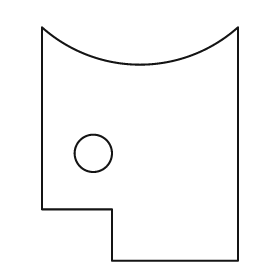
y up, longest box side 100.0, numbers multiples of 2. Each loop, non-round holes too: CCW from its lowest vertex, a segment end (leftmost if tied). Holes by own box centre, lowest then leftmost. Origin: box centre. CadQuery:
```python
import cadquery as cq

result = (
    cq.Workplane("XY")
    .moveTo(-12.0, -50.0)
    .lineTo(42.0, -50.0)
    .lineTo(42.0, 50.0)
    .threePointArc((0.0, 34.0), (-42.0, 50.0))
    .lineTo(-42.0, -28.0)
    .lineTo(-12.0, -28.0)
    .close()
    .moveTo(-20.0, -4.0)
    .circle(8.0)
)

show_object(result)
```